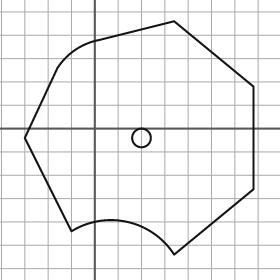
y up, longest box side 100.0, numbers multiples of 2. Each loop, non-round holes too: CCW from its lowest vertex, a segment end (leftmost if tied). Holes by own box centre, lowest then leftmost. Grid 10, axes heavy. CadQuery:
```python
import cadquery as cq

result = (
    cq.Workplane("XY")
    .moveTo(34.0, -54.0)
    .lineTo(68.0, -26.0)
    .lineTo(68.0, 18.0)
    .lineTo(34.0, 46.0)
    .lineTo(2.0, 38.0)
    .threePointArc((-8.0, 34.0), (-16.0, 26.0))
    .lineTo(-30.0, -4.0)
    .lineTo(-10.0, -44.0)
    .threePointArc((14.0, -40.0), (34.0, -54.0))
    .close()
    .moveTo(20.0, -4.0)
    .circle(4.0)
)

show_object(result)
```